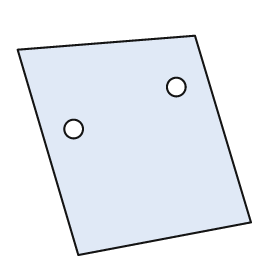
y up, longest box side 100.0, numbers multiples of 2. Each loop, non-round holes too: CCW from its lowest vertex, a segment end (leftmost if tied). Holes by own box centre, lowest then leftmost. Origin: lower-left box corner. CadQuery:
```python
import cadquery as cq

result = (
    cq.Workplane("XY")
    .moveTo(26.0, 0.0)
    .lineTo(100.0, 14.0)
    .lineTo(76.0, 94.0)
    .lineTo(0.0, 88.0)
    .close()
    .moveTo(24.0, 54.0)
    .circle(4.0)
    .moveTo(68.0, 72.0)
    .circle(4.0)
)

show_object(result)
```